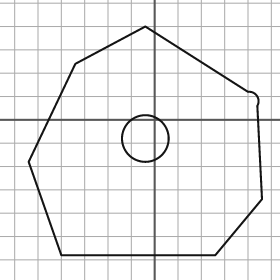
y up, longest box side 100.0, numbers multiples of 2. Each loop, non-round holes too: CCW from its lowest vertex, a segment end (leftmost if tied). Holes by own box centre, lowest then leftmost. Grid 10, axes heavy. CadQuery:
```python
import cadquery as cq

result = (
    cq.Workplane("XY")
    .moveTo(-40.0, -58.0)
    .lineTo(26.0, -58.0)
    .lineTo(46.0, -34.0)
    .lineTo(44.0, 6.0)
    .threePointArc((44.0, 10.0), (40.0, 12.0))
    .lineTo(-4.0, 40.0)
    .lineTo(-34.0, 24.0)
    .lineTo(-54.0, -18.0)
    .close()
    .moveTo(-4.0, -8.0)
    .circle(10.0)
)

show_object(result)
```